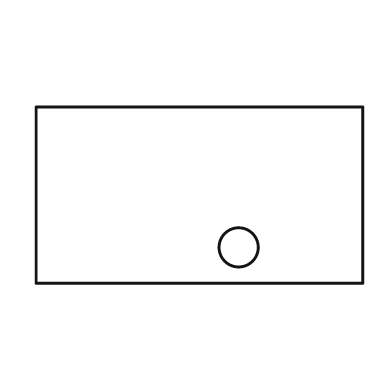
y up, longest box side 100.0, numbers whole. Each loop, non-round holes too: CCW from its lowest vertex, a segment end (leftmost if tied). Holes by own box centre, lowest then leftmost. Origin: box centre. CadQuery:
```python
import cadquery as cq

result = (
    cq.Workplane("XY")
    .moveTo(-50.0, -27.0)
    .lineTo(50.0, -27.0)
    .lineTo(50.0, 27.0)
    .lineTo(-50.0, 27.0)
    .close()
    .moveTo(12.0, -16.0)
    .circle(6.0)
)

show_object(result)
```